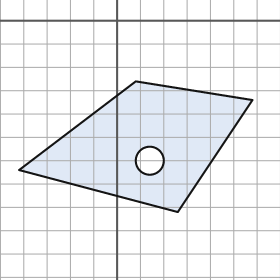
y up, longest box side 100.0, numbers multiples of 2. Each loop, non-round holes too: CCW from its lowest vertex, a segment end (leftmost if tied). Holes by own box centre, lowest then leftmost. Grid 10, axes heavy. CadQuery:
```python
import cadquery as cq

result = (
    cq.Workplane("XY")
    .moveTo(26.0, -82.0)
    .lineTo(58.0, -34.0)
    .lineTo(8.0, -26.0)
    .lineTo(-42.0, -64.0)
    .close()
    .moveTo(14.0, -60.0)
    .circle(6.0)
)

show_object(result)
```